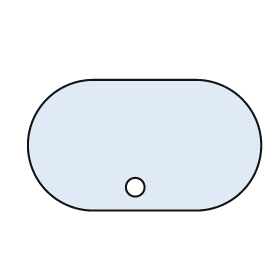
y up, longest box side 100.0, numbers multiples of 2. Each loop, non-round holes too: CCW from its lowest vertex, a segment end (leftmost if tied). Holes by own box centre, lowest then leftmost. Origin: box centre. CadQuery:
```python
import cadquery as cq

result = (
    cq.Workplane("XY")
    .moveTo(-22.0, -28.0)
    .lineTo(22.0, -28.0)
    .threePointArc((50.0, 0.0), (22.0, 28.0))
    .lineTo(-22.0, 28.0)
    .threePointArc((-50.0, 0.0), (-22.0, -28.0))
    .close()
    .moveTo(-4.0, -18.0)
    .circle(4.0)
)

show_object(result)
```